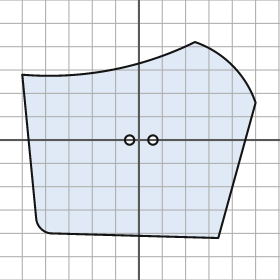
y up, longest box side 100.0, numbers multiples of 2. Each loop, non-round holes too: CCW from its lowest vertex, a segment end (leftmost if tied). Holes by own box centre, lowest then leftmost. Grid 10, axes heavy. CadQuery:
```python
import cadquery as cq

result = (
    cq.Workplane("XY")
    .moveTo(34.0, -42.0)
    .lineTo(50.0, 16.0)
    .threePointArc((40.0, 32.0), (24.0, 42.0))
    .threePointArc((-12.0, 30.0), (-50.0, 28.0))
    .lineTo(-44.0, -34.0)
    .threePointArc((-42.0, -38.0), (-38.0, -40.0))
    .close()
    .moveTo(-4.0, 0.0)
    .circle(2.0)
    .moveTo(6.0, 0.0)
    .circle(2.0)
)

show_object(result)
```